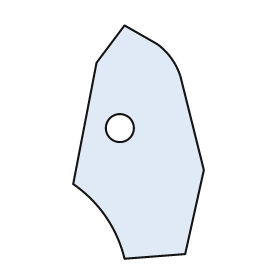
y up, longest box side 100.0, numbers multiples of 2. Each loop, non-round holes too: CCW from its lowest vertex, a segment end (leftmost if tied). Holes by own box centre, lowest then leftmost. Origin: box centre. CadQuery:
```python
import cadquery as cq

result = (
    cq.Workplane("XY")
    .moveTo(-6.0, -50.0)
    .lineTo(20.0, -48.0)
    .lineTo(28.0, -12.0)
    .lineTo(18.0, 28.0)
    .threePointArc((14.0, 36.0), (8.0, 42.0))
    .lineTo(-6.0, 50.0)
    .lineTo(-18.0, 34.0)
    .lineTo(-28.0, -18.0)
    .threePointArc((-14.0, -32.0), (-6.0, -50.0))
    .close()
    .moveTo(-8.0, 6.0)
    .circle(6.0)
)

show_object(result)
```